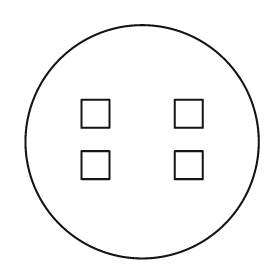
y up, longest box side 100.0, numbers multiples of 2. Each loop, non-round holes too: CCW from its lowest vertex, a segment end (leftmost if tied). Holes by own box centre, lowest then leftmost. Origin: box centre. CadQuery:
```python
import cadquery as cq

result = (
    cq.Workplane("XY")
    .moveTo(0.0, 0.0)
    .circle(50.0)
    .moveTo(-26.0, -16.0)
    .lineTo(-14.0, -16.0)
    .lineTo(-14.0, -4.0)
    .lineTo(-26.0, -4.0)
    .close()
    .moveTo(14.0, -16.0)
    .lineTo(26.0, -16.0)
    .lineTo(26.0, -4.0)
    .lineTo(14.0, -4.0)
    .close()
    .moveTo(-26.0, 6.0)
    .lineTo(-14.0, 6.0)
    .lineTo(-14.0, 18.0)
    .lineTo(-26.0, 18.0)
    .close()
    .moveTo(14.0, 6.0)
    .lineTo(26.0, 6.0)
    .lineTo(26.0, 18.0)
    .lineTo(14.0, 18.0)
    .close()
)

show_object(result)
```